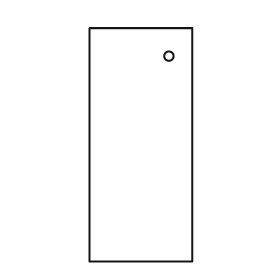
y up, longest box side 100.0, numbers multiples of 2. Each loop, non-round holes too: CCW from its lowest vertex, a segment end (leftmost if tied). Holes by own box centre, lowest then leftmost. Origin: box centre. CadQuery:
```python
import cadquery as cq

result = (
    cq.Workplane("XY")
    .moveTo(-22.0, -50.0)
    .lineTo(22.0, -50.0)
    .lineTo(22.0, 50.0)
    .lineTo(-22.0, 50.0)
    .close()
    .moveTo(12.0, 38.0)
    .circle(2.0)
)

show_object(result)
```